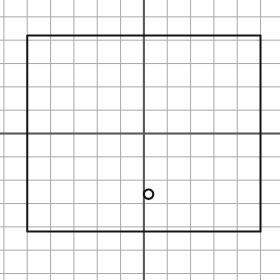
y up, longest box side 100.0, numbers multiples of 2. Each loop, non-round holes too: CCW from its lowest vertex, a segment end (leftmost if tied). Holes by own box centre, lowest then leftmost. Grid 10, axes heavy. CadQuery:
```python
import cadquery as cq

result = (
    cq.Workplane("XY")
    .moveTo(-50.0, -42.0)
    .lineTo(50.0, -42.0)
    .lineTo(50.0, 42.0)
    .lineTo(-50.0, 42.0)
    .close()
    .moveTo(2.0, -26.0)
    .circle(2.0)
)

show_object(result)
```